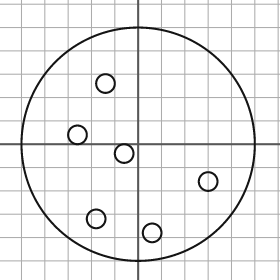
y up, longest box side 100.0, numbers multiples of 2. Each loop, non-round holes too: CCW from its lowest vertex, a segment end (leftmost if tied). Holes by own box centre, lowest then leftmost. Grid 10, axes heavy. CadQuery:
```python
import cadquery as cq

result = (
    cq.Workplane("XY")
    .moveTo(0.0, 0.0)
    .circle(50.0)
    .moveTo(6.0, -38.0)
    .circle(4.0)
    .moveTo(-18.0, -32.0)
    .circle(4.0)
    .moveTo(30.0, -16.0)
    .circle(4.0)
    .moveTo(-6.0, -4.0)
    .circle(4.0)
    .moveTo(-26.0, 4.0)
    .circle(4.0)
    .moveTo(-14.0, 26.0)
    .circle(4.0)
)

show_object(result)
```